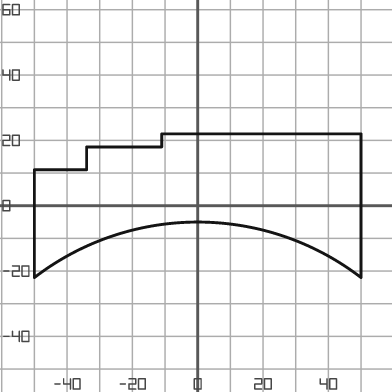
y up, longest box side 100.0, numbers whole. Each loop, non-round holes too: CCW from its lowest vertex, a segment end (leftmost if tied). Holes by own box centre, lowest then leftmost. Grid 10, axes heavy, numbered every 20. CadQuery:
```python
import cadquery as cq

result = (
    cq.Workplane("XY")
    .moveTo(-50.0, -22.0)
    .threePointArc((0.0, -5.0), (50.0, -22.0))
    .lineTo(50.0, 22.0)
    .lineTo(-11.0, 22.0)
    .lineTo(-11.0, 18.0)
    .lineTo(-34.0, 18.0)
    .lineTo(-34.0, 11.0)
    .lineTo(-50.0, 11.0)
    .close()
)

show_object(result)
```